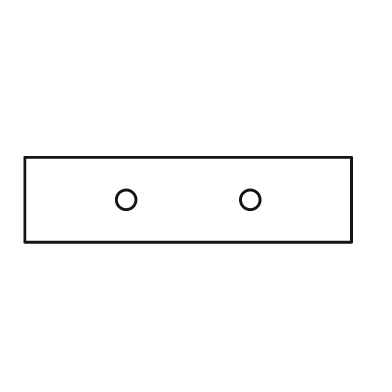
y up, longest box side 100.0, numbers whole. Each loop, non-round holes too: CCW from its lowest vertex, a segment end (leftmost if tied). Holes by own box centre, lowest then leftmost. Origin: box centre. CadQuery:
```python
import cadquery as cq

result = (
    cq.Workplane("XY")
    .moveTo(-50.0, -13.0)
    .lineTo(50.0, -13.0)
    .lineTo(50.0, 13.0)
    .lineTo(-50.0, 13.0)
    .close()
    .moveTo(-19.0, 0.0)
    .circle(3.0)
    .moveTo(19.0, 0.0)
    .circle(3.0)
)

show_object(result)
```